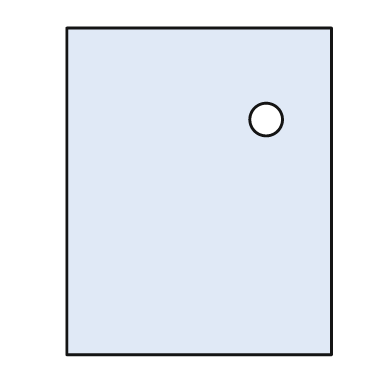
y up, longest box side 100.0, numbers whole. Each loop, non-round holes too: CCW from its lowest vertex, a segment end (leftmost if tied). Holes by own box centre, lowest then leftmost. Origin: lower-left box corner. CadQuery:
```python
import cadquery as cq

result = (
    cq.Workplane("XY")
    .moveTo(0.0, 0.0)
    .lineTo(81.0, 0.0)
    .lineTo(81.0, 100.0)
    .lineTo(0.0, 100.0)
    .close()
    .moveTo(61.0, 72.0)
    .circle(5.0)
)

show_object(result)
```